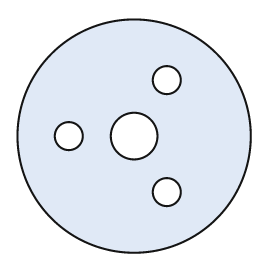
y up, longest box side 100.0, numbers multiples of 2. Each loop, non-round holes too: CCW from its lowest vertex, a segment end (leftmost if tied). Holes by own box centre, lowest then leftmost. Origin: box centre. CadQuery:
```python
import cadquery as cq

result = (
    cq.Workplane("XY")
    .moveTo(0.0, 0.0)
    .circle(50.0)
    .moveTo(14.0, -24.0)
    .circle(6.0)
    .moveTo(-28.0, 0.0)
    .circle(6.0)
    .moveTo(0.0, 0.0)
    .circle(10.0)
    .moveTo(14.0, 24.0)
    .circle(6.0)
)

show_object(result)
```